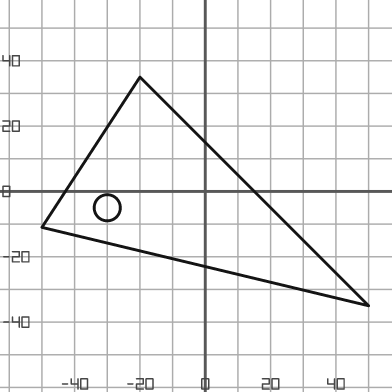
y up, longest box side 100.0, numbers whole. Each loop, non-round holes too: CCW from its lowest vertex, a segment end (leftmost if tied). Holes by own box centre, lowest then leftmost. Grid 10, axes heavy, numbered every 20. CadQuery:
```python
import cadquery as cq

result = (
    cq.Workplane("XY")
    .moveTo(50.0, -35.0)
    .lineTo(-20.0, 35.0)
    .lineTo(-50.0, -11.0)
    .close()
    .moveTo(-30.0, -5.0)
    .circle(4.0)
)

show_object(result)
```